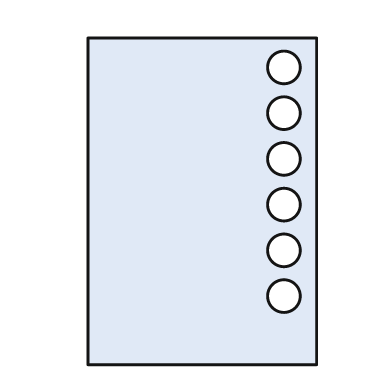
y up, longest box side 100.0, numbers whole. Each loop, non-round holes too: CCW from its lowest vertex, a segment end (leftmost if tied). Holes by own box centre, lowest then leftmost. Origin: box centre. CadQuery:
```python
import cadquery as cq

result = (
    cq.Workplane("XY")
    .moveTo(-35.0, -50.0)
    .lineTo(35.0, -50.0)
    .lineTo(35.0, 50.0)
    .lineTo(-35.0, 50.0)
    .close()
    .moveTo(25.0, -29.0)
    .circle(5.0)
    .moveTo(25.0, -15.0)
    .circle(5.0)
    .moveTo(25.0, -1.0)
    .circle(5.0)
    .moveTo(25.0, 13.0)
    .circle(5.0)
    .moveTo(25.0, 27.0)
    .circle(5.0)
    .moveTo(25.0, 41.0)
    .circle(5.0)
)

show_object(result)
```